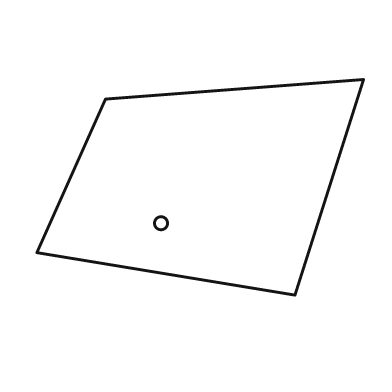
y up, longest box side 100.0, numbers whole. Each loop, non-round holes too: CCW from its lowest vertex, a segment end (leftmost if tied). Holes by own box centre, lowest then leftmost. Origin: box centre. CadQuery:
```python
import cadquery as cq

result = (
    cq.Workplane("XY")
    .moveTo(29.0, -33.0)
    .lineTo(50.0, 33.0)
    .lineTo(-29.0, 27.0)
    .lineTo(-50.0, -20.0)
    .close()
    .moveTo(-12.0, -11.0)
    .circle(2.0)
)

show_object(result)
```